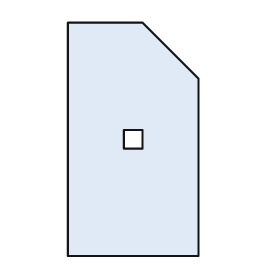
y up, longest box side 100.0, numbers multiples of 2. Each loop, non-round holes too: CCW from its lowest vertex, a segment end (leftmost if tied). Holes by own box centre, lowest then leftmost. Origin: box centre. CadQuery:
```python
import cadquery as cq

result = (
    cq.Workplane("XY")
    .moveTo(-28.0, -50.0)
    .lineTo(28.0, -50.0)
    .lineTo(28.0, 26.0)
    .lineTo(4.0, 50.0)
    .lineTo(-28.0, 50.0)
    .close()
    .moveTo(-4.0, -4.0)
    .lineTo(4.0, -4.0)
    .lineTo(4.0, 4.0)
    .lineTo(-4.0, 4.0)
    .close()
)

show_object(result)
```